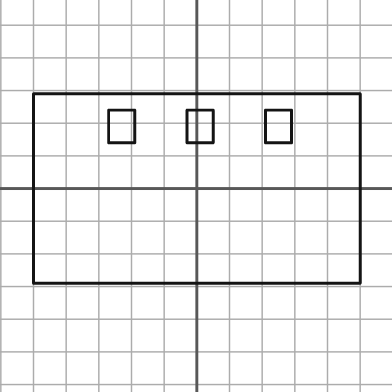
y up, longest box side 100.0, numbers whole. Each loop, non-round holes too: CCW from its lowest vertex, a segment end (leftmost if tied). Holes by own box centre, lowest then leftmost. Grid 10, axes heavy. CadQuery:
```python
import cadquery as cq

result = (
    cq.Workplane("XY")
    .moveTo(-50.0, -29.0)
    .lineTo(50.0, -29.0)
    .lineTo(50.0, 29.0)
    .lineTo(-50.0, 29.0)
    .close()
    .moveTo(-27.0, 14.0)
    .lineTo(-19.0, 14.0)
    .lineTo(-19.0, 24.0)
    .lineTo(-27.0, 24.0)
    .close()
    .moveTo(-3.0, 14.0)
    .lineTo(5.0, 14.0)
    .lineTo(5.0, 24.0)
    .lineTo(-3.0, 24.0)
    .close()
    .moveTo(21.0, 14.0)
    .lineTo(29.0, 14.0)
    .lineTo(29.0, 24.0)
    .lineTo(21.0, 24.0)
    .close()
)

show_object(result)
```